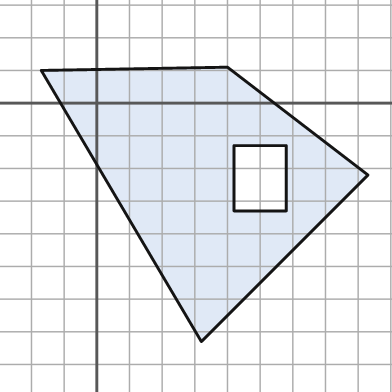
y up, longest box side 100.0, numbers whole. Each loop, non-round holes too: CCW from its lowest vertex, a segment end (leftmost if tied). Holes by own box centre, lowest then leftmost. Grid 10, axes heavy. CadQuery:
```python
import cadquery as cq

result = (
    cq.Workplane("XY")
    .moveTo(32.0, -73.0)
    .lineTo(83.0, -22.0)
    .lineTo(40.0, 11.0)
    .lineTo(-17.0, 10.0)
    .close()
    .moveTo(42.0, -33.0)
    .lineTo(58.0, -33.0)
    .lineTo(58.0, -13.0)
    .lineTo(42.0, -13.0)
    .close()
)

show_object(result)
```